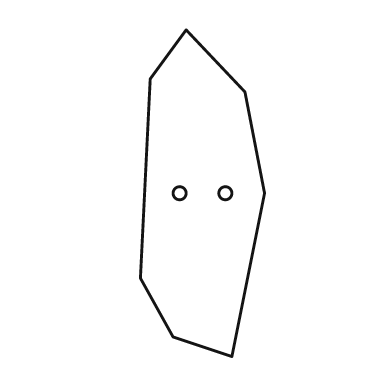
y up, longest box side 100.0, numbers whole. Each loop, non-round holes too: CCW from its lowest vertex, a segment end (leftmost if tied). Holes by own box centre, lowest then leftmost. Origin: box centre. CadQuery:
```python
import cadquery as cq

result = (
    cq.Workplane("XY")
    .moveTo(9.0, -50.0)
    .lineTo(19.0, 0.0)
    .lineTo(13.0, 31.0)
    .lineTo(-5.0, 50.0)
    .lineTo(-16.0, 35.0)
    .lineTo(-19.0, -26.0)
    .lineTo(-9.0, -44.0)
    .close()
    .moveTo(-7.0, 0.0)
    .circle(2.0)
    .moveTo(7.0, 0.0)
    .circle(2.0)
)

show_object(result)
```